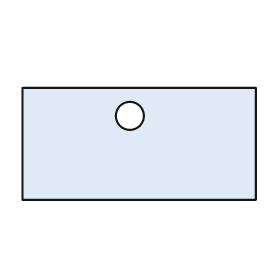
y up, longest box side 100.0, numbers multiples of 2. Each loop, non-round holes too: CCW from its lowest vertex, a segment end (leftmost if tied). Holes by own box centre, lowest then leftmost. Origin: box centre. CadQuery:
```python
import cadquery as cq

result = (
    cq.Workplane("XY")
    .moveTo(-50.0, -24.0)
    .lineTo(50.0, -24.0)
    .lineTo(50.0, 24.0)
    .lineTo(-50.0, 24.0)
    .close()
    .moveTo(-4.0, 12.0)
    .circle(6.0)
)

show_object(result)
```